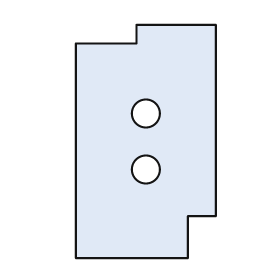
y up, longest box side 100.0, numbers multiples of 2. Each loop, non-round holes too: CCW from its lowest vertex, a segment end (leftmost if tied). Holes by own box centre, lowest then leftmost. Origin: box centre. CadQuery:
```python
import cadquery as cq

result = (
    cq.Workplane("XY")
    .moveTo(-30.0, -50.0)
    .lineTo(18.0, -50.0)
    .lineTo(18.0, -32.0)
    .lineTo(30.0, -32.0)
    .lineTo(30.0, 50.0)
    .lineTo(-4.0, 50.0)
    .lineTo(-4.0, 42.0)
    .lineTo(-30.0, 42.0)
    .close()
    .moveTo(0.0, -12.0)
    .circle(6.0)
    .moveTo(0.0, 12.0)
    .circle(6.0)
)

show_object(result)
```